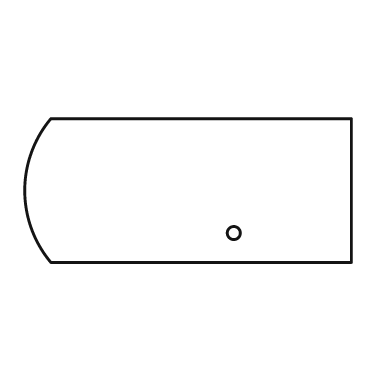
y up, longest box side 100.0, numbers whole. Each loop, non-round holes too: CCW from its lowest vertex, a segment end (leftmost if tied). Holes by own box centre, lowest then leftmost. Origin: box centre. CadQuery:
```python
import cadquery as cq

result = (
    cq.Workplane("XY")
    .moveTo(-42.0, -22.0)
    .lineTo(50.0, -22.0)
    .lineTo(50.0, 22.0)
    .lineTo(-42.0, 22.0)
    .threePointArc((-50.0, 0.0), (-42.0, -22.0))
    .close()
    .moveTo(14.0, -13.0)
    .circle(2.0)
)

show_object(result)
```